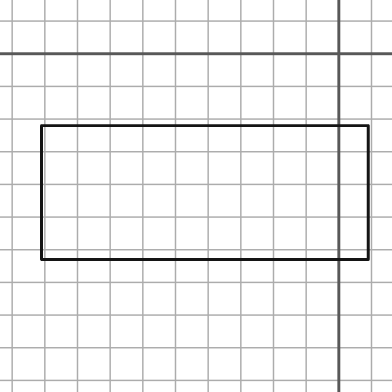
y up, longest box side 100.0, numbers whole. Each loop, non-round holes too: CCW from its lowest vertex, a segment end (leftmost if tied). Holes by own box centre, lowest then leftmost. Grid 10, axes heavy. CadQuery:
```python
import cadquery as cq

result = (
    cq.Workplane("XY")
    .moveTo(-91.0, -63.0)
    .lineTo(9.0, -63.0)
    .lineTo(9.0, -22.0)
    .lineTo(-91.0, -22.0)
    .close()
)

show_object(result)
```